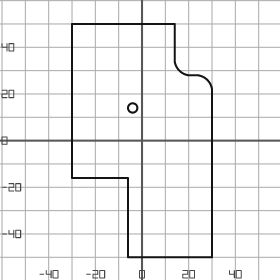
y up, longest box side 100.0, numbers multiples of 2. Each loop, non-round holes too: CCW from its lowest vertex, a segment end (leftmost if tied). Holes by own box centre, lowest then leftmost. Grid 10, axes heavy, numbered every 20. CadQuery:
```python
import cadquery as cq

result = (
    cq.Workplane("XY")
    .moveTo(-6.0, -50.0)
    .lineTo(30.0, -50.0)
    .lineTo(30.0, 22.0)
    .threePointArc((28.0, 26.0), (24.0, 28.0))
    .lineTo(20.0, 28.0)
    .threePointArc((16.0, 30.0), (14.0, 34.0))
    .lineTo(14.0, 50.0)
    .lineTo(-30.0, 50.0)
    .lineTo(-30.0, -16.0)
    .lineTo(-6.0, -16.0)
    .close()
    .moveTo(-4.0, 14.0)
    .circle(2.0)
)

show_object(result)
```